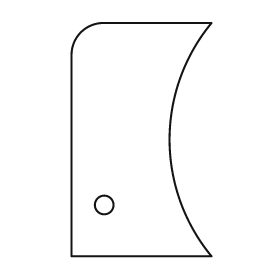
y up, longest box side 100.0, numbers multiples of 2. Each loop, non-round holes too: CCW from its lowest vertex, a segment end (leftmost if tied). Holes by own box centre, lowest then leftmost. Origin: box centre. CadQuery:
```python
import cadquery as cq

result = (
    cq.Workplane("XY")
    .moveTo(-30.0, -50.0)
    .lineTo(30.0, -50.0)
    .threePointArc((12.0, 0.0), (30.0, 50.0))
    .lineTo(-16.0, 50.0)
    .threePointArc((-26.0, 46.0), (-30.0, 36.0))
    .close()
    .moveTo(-16.0, -28.0)
    .circle(4.0)
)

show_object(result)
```